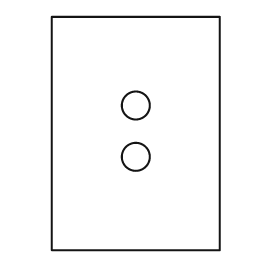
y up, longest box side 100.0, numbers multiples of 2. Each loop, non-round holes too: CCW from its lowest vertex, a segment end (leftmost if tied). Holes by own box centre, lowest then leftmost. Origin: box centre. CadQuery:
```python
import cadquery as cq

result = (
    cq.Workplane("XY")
    .moveTo(-36.0, -50.0)
    .lineTo(36.0, -50.0)
    .lineTo(36.0, 50.0)
    .lineTo(-36.0, 50.0)
    .close()
    .moveTo(0.0, -10.0)
    .circle(6.0)
    .moveTo(0.0, 12.0)
    .circle(6.0)
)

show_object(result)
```